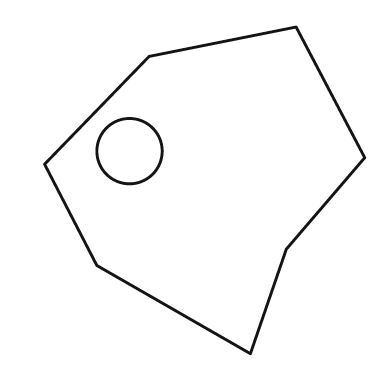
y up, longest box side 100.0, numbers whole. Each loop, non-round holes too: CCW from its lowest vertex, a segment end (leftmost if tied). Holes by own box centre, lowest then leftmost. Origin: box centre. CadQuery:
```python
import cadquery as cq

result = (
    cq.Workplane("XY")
    .moveTo(14.0, -50.0)
    .lineTo(25.0, -18.0)
    .lineTo(49.0, 10.0)
    .lineTo(28.0, 50.0)
    .lineTo(-17.0, 41.0)
    .lineTo(-49.0, 8.0)
    .lineTo(-33.0, -23.0)
    .close()
    .moveTo(-23.0, 12.0)
    .circle(10.0)
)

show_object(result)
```